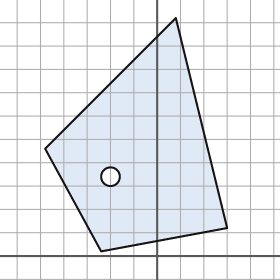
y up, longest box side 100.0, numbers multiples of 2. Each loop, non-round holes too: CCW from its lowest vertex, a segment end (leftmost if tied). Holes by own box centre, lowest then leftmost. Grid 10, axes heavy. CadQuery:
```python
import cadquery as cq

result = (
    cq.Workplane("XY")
    .moveTo(-24.0, 2.0)
    .lineTo(30.0, 12.0)
    .lineTo(8.0, 102.0)
    .lineTo(-48.0, 46.0)
    .close()
    .moveTo(-20.0, 34.0)
    .circle(4.0)
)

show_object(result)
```